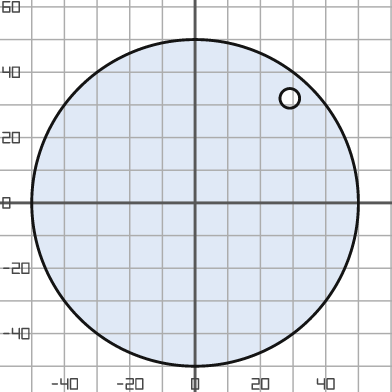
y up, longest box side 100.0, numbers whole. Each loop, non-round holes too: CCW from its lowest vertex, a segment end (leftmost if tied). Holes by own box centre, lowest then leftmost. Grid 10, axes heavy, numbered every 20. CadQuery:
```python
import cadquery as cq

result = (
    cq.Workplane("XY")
    .moveTo(0.0, 0.0)
    .circle(50.0)
    .moveTo(29.0, 32.0)
    .circle(3.0)
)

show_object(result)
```